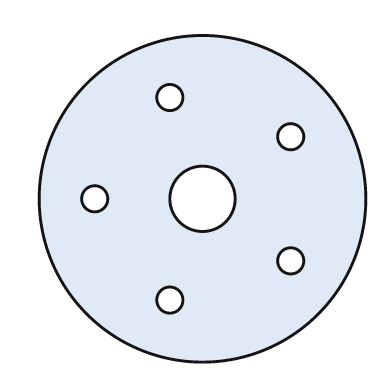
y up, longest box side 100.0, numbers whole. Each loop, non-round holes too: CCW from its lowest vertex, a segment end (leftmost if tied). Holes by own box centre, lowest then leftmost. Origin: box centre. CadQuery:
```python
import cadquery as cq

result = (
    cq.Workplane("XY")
    .moveTo(0.0, 0.0)
    .circle(50.0)
    .moveTo(-10.0, -31.0)
    .circle(4.0)
    .moveTo(27.0, -19.0)
    .circle(4.0)
    .moveTo(-33.0, 0.0)
    .circle(4.0)
    .moveTo(0.0, 0.0)
    .circle(10.0)
    .moveTo(27.0, 19.0)
    .circle(4.0)
    .moveTo(-10.0, 31.0)
    .circle(4.0)
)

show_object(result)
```